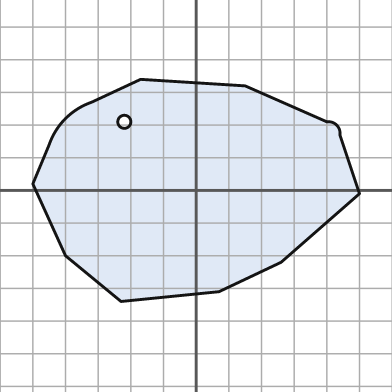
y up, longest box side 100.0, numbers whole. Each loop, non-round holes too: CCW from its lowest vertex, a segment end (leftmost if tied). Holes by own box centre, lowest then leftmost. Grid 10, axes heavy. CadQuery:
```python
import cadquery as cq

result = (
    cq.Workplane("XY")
    .moveTo(-23.0, -34.0)
    .lineTo(7.0, -31.0)
    .lineTo(26.0, -22.0)
    .lineTo(50.0, -1.0)
    .lineTo(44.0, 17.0)
    .threePointArc((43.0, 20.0), (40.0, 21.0))
    .lineTo(15.0, 32.0)
    .lineTo(-17.0, 34.0)
    .lineTo(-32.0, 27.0)
    .threePointArc((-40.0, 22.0), (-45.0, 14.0))
    .lineTo(-50.0, 2.0)
    .lineTo(-40.0, -20.0)
    .close()
    .moveTo(-22.0, 21.0)
    .circle(2.0)
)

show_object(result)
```